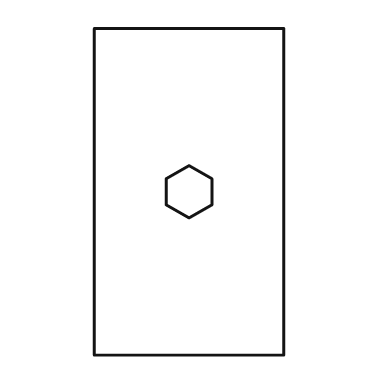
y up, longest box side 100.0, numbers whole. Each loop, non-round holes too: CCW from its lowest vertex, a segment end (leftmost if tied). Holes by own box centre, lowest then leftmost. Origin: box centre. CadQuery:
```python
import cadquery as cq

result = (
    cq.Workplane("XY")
    .moveTo(-29.0, -50.0)
    .lineTo(29.0, -50.0)
    .lineTo(29.0, 50.0)
    .lineTo(-29.0, 50.0)
    .close()
    .moveTo(0.0, -8.0)
    .lineTo(7.0, -4.0)
    .lineTo(7.0, 4.0)
    .lineTo(0.0, 8.0)
    .lineTo(-7.0, 4.0)
    .lineTo(-7.0, -4.0)
    .close()
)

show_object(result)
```